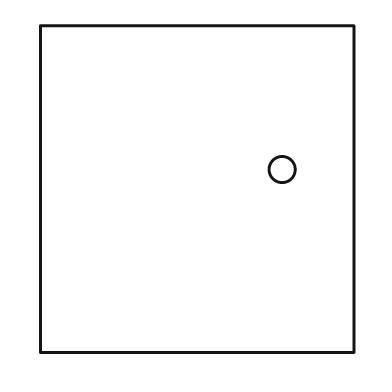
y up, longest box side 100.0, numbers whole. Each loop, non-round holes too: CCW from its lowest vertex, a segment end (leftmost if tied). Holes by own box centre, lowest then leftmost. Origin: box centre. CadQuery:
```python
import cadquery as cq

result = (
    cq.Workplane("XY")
    .moveTo(-48.0, -50.0)
    .lineTo(48.0, -50.0)
    .lineTo(48.0, 50.0)
    .lineTo(-48.0, 50.0)
    .close()
    .moveTo(26.0, 6.0)
    .circle(4.0)
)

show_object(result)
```